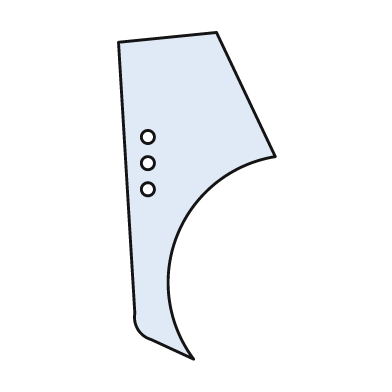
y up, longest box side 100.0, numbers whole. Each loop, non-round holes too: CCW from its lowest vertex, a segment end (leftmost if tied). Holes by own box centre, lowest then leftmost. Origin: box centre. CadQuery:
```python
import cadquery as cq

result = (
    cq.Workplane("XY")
    .moveTo(-1.0, -50.0)
    .threePointArc((-6.0, -12.0), (24.0, 12.0))
    .lineTo(6.0, 50.0)
    .lineTo(-24.0, 47.0)
    .lineTo(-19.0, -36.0)
    .threePointArc((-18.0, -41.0), (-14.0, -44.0))
    .close()
    .moveTo(-15.0, 2.0)
    .circle(2.0)
    .moveTo(-15.0, 10.0)
    .circle(2.0)
    .moveTo(-15.0, 18.0)
    .circle(2.0)
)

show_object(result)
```